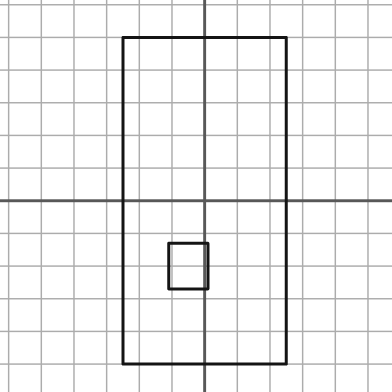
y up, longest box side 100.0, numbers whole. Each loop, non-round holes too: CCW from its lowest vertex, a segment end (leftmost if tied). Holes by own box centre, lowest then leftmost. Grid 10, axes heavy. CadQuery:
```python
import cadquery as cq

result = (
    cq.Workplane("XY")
    .moveTo(-25.0, -50.0)
    .lineTo(25.0, -50.0)
    .lineTo(25.0, 50.0)
    .lineTo(-25.0, 50.0)
    .close()
    .moveTo(-11.0, -27.0)
    .lineTo(1.0, -27.0)
    .lineTo(1.0, -13.0)
    .lineTo(-11.0, -13.0)
    .close()
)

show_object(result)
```